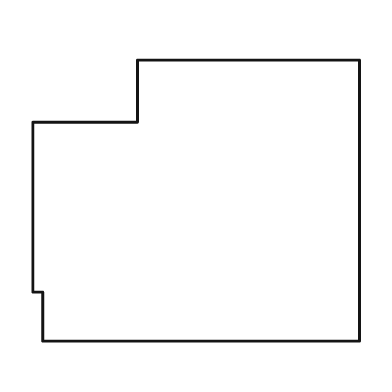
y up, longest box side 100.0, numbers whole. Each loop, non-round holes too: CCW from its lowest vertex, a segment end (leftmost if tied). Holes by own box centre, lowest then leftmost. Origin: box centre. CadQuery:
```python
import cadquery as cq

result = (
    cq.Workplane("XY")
    .moveTo(-47.0, -43.0)
    .lineTo(50.0, -43.0)
    .lineTo(50.0, 43.0)
    .lineTo(-18.0, 43.0)
    .lineTo(-18.0, 24.0)
    .lineTo(-50.0, 24.0)
    .lineTo(-50.0, -28.0)
    .lineTo(-47.0, -28.0)
    .close()
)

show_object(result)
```